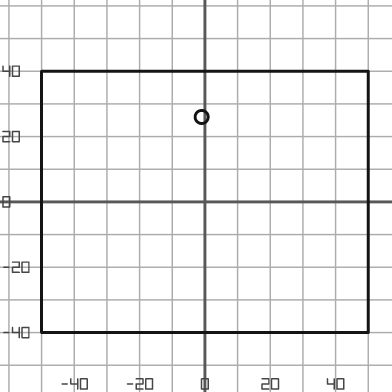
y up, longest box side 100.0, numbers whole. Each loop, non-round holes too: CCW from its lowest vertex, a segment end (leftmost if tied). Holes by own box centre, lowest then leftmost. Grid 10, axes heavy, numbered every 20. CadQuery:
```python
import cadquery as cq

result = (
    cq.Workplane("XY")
    .moveTo(-50.0, -40.0)
    .lineTo(50.0, -40.0)
    .lineTo(50.0, 40.0)
    .lineTo(-50.0, 40.0)
    .close()
    .moveTo(-1.0, 26.0)
    .circle(2.0)
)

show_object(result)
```